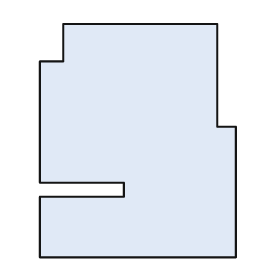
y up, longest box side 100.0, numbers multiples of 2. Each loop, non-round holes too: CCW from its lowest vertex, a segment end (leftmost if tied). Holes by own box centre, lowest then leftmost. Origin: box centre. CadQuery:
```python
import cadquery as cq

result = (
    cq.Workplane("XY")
    .moveTo(-42.0, -50.0)
    .lineTo(42.0, -50.0)
    .lineTo(42.0, 6.0)
    .lineTo(34.0, 6.0)
    .lineTo(34.0, 50.0)
    .lineTo(-32.0, 50.0)
    .lineTo(-32.0, 34.0)
    .lineTo(-42.0, 34.0)
    .lineTo(-42.0, -18.0)
    .lineTo(-6.0, -18.0)
    .lineTo(-6.0, -24.0)
    .lineTo(-42.0, -24.0)
    .close()
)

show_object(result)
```